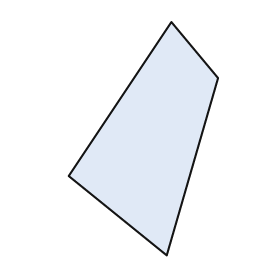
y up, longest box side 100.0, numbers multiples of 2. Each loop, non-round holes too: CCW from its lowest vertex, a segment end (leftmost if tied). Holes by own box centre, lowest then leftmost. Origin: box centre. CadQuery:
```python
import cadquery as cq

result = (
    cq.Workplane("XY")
    .moveTo(10.0, -50.0)
    .lineTo(32.0, 26.0)
    .lineTo(12.0, 50.0)
    .lineTo(-32.0, -16.0)
    .close()
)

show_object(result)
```